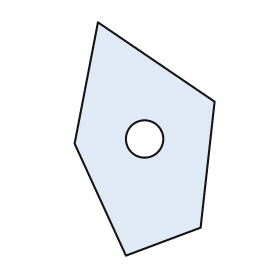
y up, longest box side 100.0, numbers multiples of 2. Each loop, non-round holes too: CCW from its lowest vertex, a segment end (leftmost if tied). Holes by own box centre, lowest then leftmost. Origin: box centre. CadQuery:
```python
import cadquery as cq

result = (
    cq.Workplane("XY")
    .moveTo(-8.0, -50.0)
    .lineTo(24.0, -38.0)
    .lineTo(30.0, 16.0)
    .lineTo(-20.0, 50.0)
    .lineTo(-30.0, -2.0)
    .close()
    .moveTo(0.0, 0.0)
    .circle(8.0)
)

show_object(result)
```